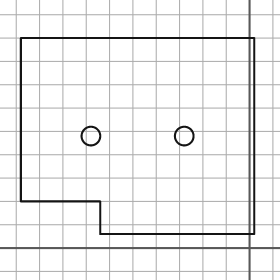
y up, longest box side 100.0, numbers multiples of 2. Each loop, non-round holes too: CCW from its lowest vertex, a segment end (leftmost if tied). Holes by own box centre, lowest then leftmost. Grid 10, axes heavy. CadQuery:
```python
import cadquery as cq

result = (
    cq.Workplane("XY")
    .moveTo(-64.0, 6.0)
    .lineTo(2.0, 6.0)
    .lineTo(2.0, 90.0)
    .lineTo(-98.0, 90.0)
    .lineTo(-98.0, 20.0)
    .lineTo(-64.0, 20.0)
    .close()
    .moveTo(-68.0, 48.0)
    .circle(4.0)
    .moveTo(-28.0, 48.0)
    .circle(4.0)
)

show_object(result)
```